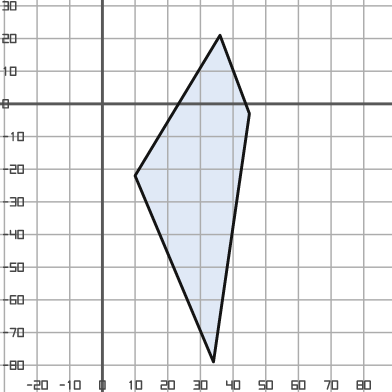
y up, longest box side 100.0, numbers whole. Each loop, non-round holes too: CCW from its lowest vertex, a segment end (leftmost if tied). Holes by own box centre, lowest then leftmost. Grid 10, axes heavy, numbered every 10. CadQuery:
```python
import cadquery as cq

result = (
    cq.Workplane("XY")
    .moveTo(34.0, -79.0)
    .lineTo(45.0, -3.0)
    .lineTo(36.0, 21.0)
    .lineTo(10.0, -22.0)
    .close()
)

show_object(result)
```